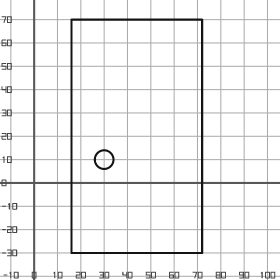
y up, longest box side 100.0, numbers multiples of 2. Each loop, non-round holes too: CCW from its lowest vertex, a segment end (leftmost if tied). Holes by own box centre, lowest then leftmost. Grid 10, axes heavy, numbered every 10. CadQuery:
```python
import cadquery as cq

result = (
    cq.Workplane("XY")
    .moveTo(16.0, -30.0)
    .lineTo(72.0, -30.0)
    .lineTo(72.0, 70.0)
    .lineTo(16.0, 70.0)
    .close()
    .moveTo(30.0, 10.0)
    .circle(4.0)
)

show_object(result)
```